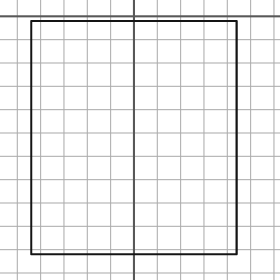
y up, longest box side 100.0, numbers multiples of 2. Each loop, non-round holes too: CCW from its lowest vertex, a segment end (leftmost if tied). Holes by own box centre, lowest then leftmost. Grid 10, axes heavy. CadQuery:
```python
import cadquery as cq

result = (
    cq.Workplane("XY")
    .moveTo(-44.0, -102.0)
    .lineTo(44.0, -102.0)
    .lineTo(44.0, -2.0)
    .lineTo(-44.0, -2.0)
    .close()
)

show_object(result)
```